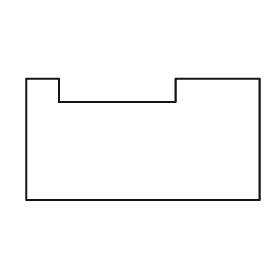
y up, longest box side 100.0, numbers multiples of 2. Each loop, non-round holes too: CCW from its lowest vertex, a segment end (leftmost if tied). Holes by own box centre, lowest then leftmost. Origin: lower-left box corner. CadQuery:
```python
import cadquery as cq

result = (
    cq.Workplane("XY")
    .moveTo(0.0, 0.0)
    .lineTo(100.0, 0.0)
    .lineTo(100.0, 52.0)
    .lineTo(64.0, 52.0)
    .lineTo(64.0, 42.0)
    .lineTo(14.0, 42.0)
    .lineTo(14.0, 52.0)
    .lineTo(0.0, 52.0)
    .close()
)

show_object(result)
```